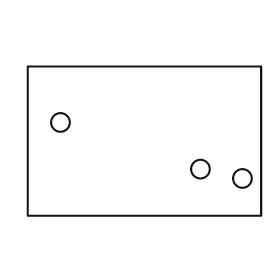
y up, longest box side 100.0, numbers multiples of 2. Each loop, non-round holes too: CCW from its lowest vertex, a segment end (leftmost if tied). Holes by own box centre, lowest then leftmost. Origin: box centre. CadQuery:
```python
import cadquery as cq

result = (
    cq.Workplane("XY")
    .moveTo(-50.0, -32.0)
    .lineTo(50.0, -32.0)
    .lineTo(50.0, 32.0)
    .lineTo(-50.0, 32.0)
    .close()
    .moveTo(42.0, -16.0)
    .circle(4.0)
    .moveTo(24.0, -12.0)
    .circle(4.0)
    .moveTo(-36.0, 8.0)
    .circle(4.0)
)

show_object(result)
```